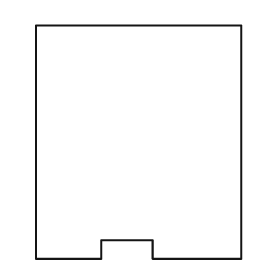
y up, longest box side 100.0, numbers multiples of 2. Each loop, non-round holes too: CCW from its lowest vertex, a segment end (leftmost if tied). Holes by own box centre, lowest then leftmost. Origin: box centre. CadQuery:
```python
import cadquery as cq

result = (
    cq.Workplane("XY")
    .moveTo(-44.0, -50.0)
    .lineTo(-16.0, -50.0)
    .lineTo(-16.0, -42.0)
    .lineTo(6.0, -42.0)
    .lineTo(6.0, -50.0)
    .lineTo(44.0, -50.0)
    .lineTo(44.0, 50.0)
    .lineTo(-44.0, 50.0)
    .close()
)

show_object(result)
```